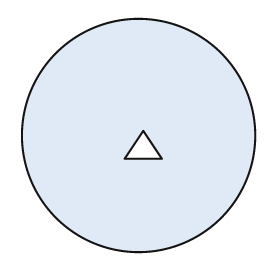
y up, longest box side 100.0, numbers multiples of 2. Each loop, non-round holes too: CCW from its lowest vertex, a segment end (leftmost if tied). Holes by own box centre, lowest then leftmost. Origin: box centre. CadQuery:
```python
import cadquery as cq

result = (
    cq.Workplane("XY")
    .moveTo(0.0, 0.0)
    .circle(50.0)
    .moveTo(-6.0, -10.0)
    .lineTo(10.0, -10.0)
    .lineTo(2.0, 2.0)
    .close()
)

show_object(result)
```